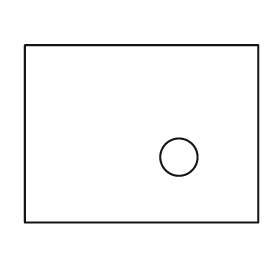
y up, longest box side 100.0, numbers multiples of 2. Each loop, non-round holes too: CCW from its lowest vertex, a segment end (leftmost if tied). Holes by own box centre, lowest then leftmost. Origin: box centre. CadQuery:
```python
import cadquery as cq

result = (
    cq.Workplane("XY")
    .moveTo(-50.0, -38.0)
    .lineTo(50.0, -38.0)
    .lineTo(50.0, 38.0)
    .lineTo(-50.0, 38.0)
    .close()
    .moveTo(16.0, -10.0)
    .circle(8.0)
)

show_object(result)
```